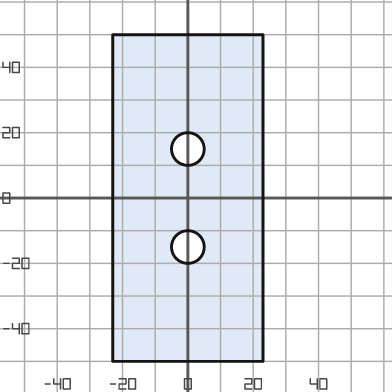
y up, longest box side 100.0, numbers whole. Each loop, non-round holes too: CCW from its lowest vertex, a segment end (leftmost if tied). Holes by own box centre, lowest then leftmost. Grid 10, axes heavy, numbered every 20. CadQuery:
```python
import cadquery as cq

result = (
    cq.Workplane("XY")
    .moveTo(-23.0, -50.0)
    .lineTo(23.0, -50.0)
    .lineTo(23.0, 50.0)
    .lineTo(-23.0, 50.0)
    .close()
    .moveTo(0.0, -15.0)
    .circle(5.0)
    .moveTo(0.0, 15.0)
    .circle(5.0)
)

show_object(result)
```